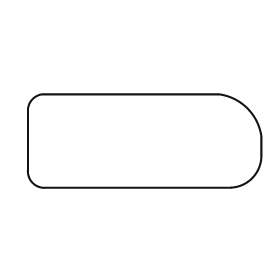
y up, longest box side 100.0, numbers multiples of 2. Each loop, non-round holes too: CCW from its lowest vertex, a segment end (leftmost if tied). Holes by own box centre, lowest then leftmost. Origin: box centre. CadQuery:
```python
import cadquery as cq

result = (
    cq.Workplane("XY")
    .moveTo(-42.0, -20.0)
    .lineTo(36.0, -20.0)
    .threePointArc((46.0, -16.0), (50.0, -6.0))
    .lineTo(50.0, 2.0)
    .threePointArc((44.0, 14.0), (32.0, 20.0))
    .lineTo(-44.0, 20.0)
    .threePointArc((-48.0, 18.0), (-50.0, 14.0))
    .lineTo(-50.0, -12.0)
    .threePointArc((-48.0, -18.0), (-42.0, -20.0))
    .close()
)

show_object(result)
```